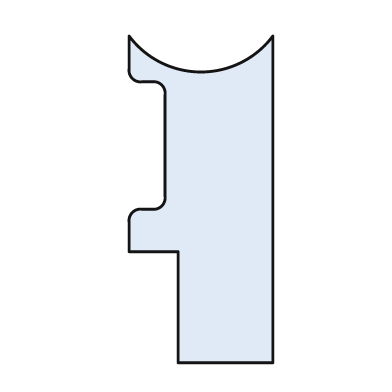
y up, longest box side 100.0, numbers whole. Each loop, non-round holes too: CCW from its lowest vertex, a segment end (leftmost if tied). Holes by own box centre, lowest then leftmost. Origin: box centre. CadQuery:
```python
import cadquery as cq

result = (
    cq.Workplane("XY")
    .moveTo(-7.0, -50.0)
    .lineTo(22.0, -50.0)
    .lineTo(22.0, 50.0)
    .threePointArc((0.0, 39.0), (-22.0, 50.0))
    .lineTo(-22.0, 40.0)
    .threePointArc((-21.0, 37.0), (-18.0, 36.0))
    .lineTo(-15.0, 36.0)
    .threePointArc((-12.0, 35.0), (-11.0, 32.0))
    .lineTo(-11.0, 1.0)
    .threePointArc((-12.0, -2.0), (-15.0, -3.0))
    .lineTo(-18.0, -3.0)
    .threePointArc((-21.0, -4.0), (-22.0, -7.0))
    .lineTo(-22.0, -16.0)
    .lineTo(-7.0, -16.0)
    .close()
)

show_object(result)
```